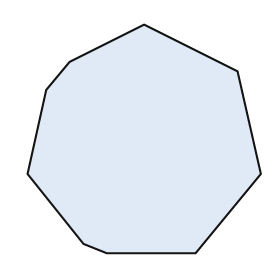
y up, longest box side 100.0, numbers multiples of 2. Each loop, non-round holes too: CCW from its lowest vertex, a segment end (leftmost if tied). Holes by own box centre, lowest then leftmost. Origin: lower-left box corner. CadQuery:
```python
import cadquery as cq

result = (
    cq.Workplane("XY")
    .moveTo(34.0, 0.0)
    .lineTo(72.0, 0.0)
    .lineTo(100.0, 34.0)
    .lineTo(90.0, 78.0)
    .lineTo(50.0, 98.0)
    .lineTo(18.0, 82.0)
    .lineTo(8.0, 70.0)
    .lineTo(0.0, 34.0)
    .lineTo(24.0, 4.0)
    .close()
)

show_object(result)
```